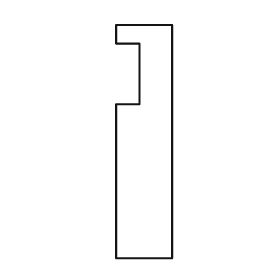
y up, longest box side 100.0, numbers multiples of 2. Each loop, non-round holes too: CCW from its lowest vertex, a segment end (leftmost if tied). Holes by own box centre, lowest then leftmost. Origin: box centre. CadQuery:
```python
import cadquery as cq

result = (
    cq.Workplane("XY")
    .moveTo(-12.0, -50.0)
    .lineTo(12.0, -50.0)
    .lineTo(12.0, 50.0)
    .lineTo(-12.0, 50.0)
    .lineTo(-12.0, 42.0)
    .lineTo(-2.0, 42.0)
    .lineTo(-2.0, 16.0)
    .lineTo(-12.0, 16.0)
    .close()
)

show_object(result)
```